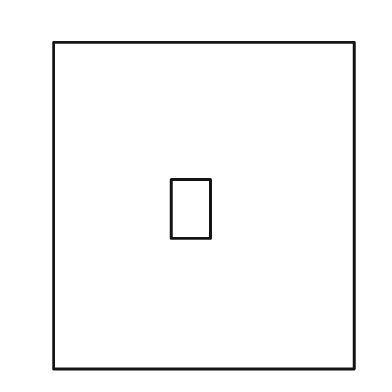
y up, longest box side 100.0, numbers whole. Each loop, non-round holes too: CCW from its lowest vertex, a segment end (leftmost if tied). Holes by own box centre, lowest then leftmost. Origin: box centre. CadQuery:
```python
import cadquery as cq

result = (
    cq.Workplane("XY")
    .moveTo(-46.0, -50.0)
    .lineTo(46.0, -50.0)
    .lineTo(46.0, 50.0)
    .lineTo(-46.0, 50.0)
    .close()
    .moveTo(-10.0, -10.0)
    .lineTo(2.0, -10.0)
    .lineTo(2.0, 8.0)
    .lineTo(-10.0, 8.0)
    .close()
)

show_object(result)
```